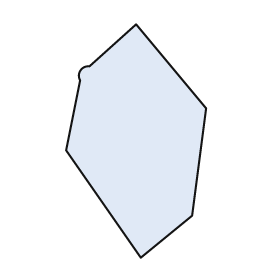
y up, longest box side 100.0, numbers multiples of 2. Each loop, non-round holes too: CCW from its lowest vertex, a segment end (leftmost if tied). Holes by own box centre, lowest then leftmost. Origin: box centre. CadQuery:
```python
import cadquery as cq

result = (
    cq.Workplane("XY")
    .moveTo(2.0, -50.0)
    .lineTo(24.0, -32.0)
    .lineTo(30.0, 14.0)
    .lineTo(0.0, 50.0)
    .lineTo(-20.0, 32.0)
    .threePointArc((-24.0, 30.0), (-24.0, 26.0))
    .lineTo(-30.0, -4.0)
    .close()
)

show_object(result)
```